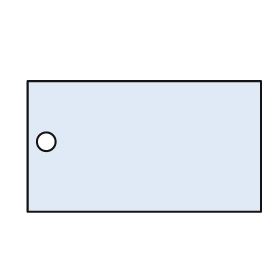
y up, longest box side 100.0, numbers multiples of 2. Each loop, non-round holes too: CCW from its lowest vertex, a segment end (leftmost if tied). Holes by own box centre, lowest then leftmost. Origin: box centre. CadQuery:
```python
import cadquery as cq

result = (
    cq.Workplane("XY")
    .moveTo(-50.0, -28.0)
    .lineTo(50.0, -28.0)
    .lineTo(50.0, 28.0)
    .lineTo(-50.0, 28.0)
    .close()
    .moveTo(-42.0, 2.0)
    .circle(4.0)
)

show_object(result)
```